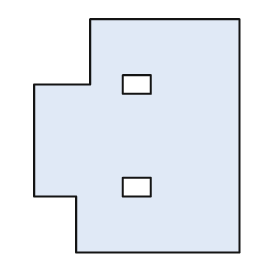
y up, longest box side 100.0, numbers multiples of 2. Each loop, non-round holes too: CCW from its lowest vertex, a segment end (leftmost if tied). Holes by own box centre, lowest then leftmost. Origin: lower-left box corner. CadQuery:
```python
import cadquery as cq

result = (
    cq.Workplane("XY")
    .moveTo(18.0, 0.0)
    .lineTo(88.0, 0.0)
    .lineTo(88.0, 100.0)
    .lineTo(24.0, 100.0)
    .lineTo(24.0, 72.0)
    .lineTo(0.0, 72.0)
    .lineTo(0.0, 24.0)
    .lineTo(18.0, 24.0)
    .close()
    .moveTo(38.0, 24.0)
    .lineTo(50.0, 24.0)
    .lineTo(50.0, 32.0)
    .lineTo(38.0, 32.0)
    .close()
    .moveTo(38.0, 68.0)
    .lineTo(50.0, 68.0)
    .lineTo(50.0, 76.0)
    .lineTo(38.0, 76.0)
    .close()
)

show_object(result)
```